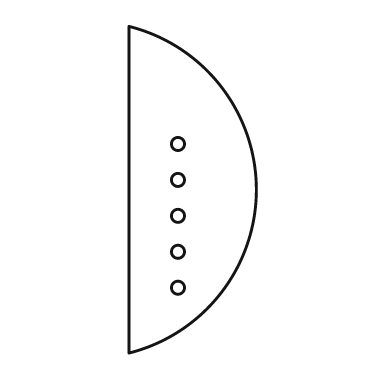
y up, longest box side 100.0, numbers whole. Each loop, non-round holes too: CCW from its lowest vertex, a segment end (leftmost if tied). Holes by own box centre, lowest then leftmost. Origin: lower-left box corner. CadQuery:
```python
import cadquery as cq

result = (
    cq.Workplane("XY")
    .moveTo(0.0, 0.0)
    .threePointArc((39.0, 50.0), (0.0, 100.0))
    .close()
    .moveTo(15.0, 20.0)
    .circle(2.0)
    .moveTo(15.0, 31.0)
    .circle(2.0)
    .moveTo(15.0, 42.0)
    .circle(2.0)
    .moveTo(15.0, 53.0)
    .circle(2.0)
    .moveTo(15.0, 64.0)
    .circle(2.0)
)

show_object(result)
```